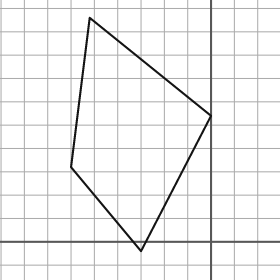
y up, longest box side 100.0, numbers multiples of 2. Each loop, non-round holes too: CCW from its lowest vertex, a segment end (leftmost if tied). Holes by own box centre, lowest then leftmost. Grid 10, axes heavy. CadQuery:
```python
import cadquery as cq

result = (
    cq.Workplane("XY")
    .moveTo(-30.0, -4.0)
    .lineTo(0.0, 54.0)
    .lineTo(-52.0, 96.0)
    .lineTo(-60.0, 32.0)
    .close()
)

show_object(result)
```